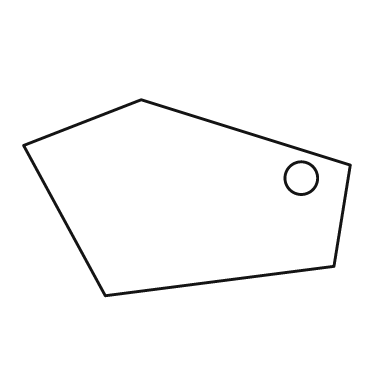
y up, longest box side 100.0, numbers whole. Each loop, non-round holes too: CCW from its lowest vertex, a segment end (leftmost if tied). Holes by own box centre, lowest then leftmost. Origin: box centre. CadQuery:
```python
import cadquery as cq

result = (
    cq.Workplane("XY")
    .moveTo(-25.0, -30.0)
    .lineTo(45.0, -21.0)
    .lineTo(50.0, 10.0)
    .lineTo(-14.0, 30.0)
    .lineTo(-50.0, 16.0)
    .close()
    .moveTo(35.0, 6.0)
    .circle(5.0)
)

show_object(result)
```